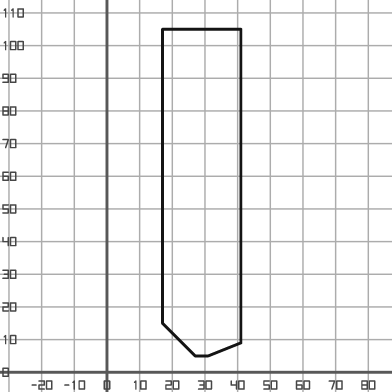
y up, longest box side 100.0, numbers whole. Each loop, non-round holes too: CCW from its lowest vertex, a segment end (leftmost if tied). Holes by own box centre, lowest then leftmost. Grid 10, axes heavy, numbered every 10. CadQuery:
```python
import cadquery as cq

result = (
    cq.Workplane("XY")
    .moveTo(27.0, 5.0)
    .lineTo(31.0, 5.0)
    .lineTo(41.0, 9.0)
    .lineTo(41.0, 105.0)
    .lineTo(17.0, 105.0)
    .lineTo(17.0, 15.0)
    .close()
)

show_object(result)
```